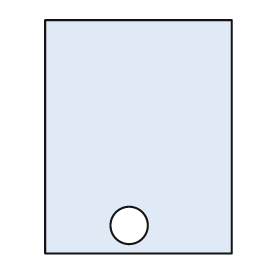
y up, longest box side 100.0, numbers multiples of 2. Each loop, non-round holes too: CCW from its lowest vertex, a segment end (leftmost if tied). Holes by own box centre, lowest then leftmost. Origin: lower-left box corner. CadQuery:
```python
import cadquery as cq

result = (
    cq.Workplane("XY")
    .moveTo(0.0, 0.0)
    .lineTo(80.0, 0.0)
    .lineTo(80.0, 100.0)
    .lineTo(0.0, 100.0)
    .close()
    .moveTo(36.0, 12.0)
    .circle(8.0)
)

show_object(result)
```